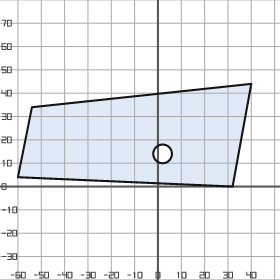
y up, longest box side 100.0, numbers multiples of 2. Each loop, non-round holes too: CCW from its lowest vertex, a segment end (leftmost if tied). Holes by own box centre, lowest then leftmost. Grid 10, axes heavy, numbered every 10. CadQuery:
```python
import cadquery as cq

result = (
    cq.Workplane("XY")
    .moveTo(32.0, 0.0)
    .lineTo(40.0, 44.0)
    .lineTo(-54.0, 34.0)
    .lineTo(-60.0, 4.0)
    .close()
    .moveTo(2.0, 14.0)
    .circle(4.0)
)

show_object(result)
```